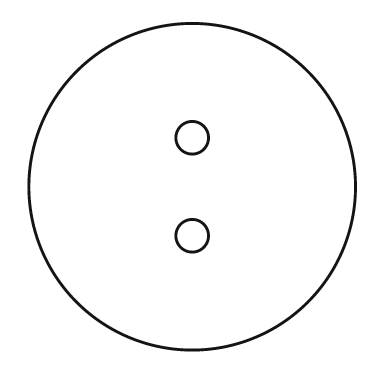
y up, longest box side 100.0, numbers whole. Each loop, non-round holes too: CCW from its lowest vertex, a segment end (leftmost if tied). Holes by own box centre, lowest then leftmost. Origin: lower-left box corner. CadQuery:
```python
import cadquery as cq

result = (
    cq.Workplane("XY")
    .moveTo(50.0, 50.0)
    .circle(50.0)
    .moveTo(50.0, 35.0)
    .circle(5.0)
    .moveTo(50.0, 65.0)
    .circle(5.0)
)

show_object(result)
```